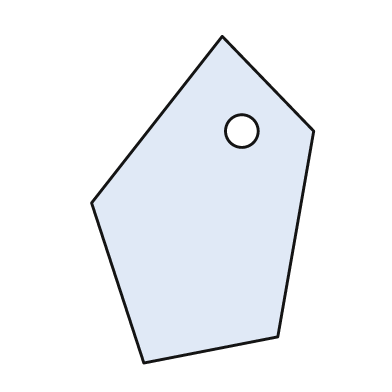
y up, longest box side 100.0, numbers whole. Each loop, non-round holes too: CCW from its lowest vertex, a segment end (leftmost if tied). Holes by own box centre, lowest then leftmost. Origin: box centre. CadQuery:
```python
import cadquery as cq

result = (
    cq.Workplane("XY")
    .moveTo(-18.0, -50.0)
    .lineTo(23.0, -42.0)
    .lineTo(34.0, 21.0)
    .lineTo(6.0, 50.0)
    .lineTo(-34.0, -1.0)
    .close()
    .moveTo(12.0, 21.0)
    .circle(5.0)
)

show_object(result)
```